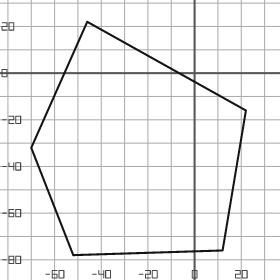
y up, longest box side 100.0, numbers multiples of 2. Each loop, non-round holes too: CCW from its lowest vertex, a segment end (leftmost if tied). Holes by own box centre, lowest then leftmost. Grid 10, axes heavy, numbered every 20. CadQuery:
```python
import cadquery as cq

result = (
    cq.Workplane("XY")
    .moveTo(-52.0, -78.0)
    .lineTo(12.0, -76.0)
    .lineTo(22.0, -16.0)
    .lineTo(-46.0, 22.0)
    .lineTo(-70.0, -32.0)
    .close()
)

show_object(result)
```